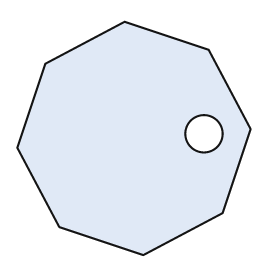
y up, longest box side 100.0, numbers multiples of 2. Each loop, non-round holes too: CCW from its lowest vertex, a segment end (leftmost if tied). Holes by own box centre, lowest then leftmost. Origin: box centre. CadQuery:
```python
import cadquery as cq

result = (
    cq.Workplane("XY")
    .moveTo(4.0, -50.0)
    .lineTo(38.0, -32.0)
    .lineTo(50.0, 4.0)
    .lineTo(32.0, 38.0)
    .lineTo(-4.0, 50.0)
    .lineTo(-38.0, 32.0)
    .lineTo(-50.0, -4.0)
    .lineTo(-32.0, -38.0)
    .close()
    .moveTo(30.0, 2.0)
    .circle(8.0)
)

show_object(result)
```